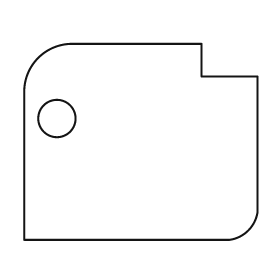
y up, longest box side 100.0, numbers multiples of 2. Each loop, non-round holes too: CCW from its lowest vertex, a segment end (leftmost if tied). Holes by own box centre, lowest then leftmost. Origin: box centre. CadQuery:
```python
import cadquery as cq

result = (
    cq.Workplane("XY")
    .moveTo(-50.0, -42.0)
    .lineTo(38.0, -42.0)
    .threePointArc((46.0, -38.0), (50.0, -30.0))
    .lineTo(50.0, 28.0)
    .lineTo(26.0, 28.0)
    .lineTo(26.0, 42.0)
    .lineTo(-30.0, 42.0)
    .threePointArc((-44.0, 36.0), (-50.0, 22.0))
    .close()
    .moveTo(-36.0, 10.0)
    .circle(8.0)
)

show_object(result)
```